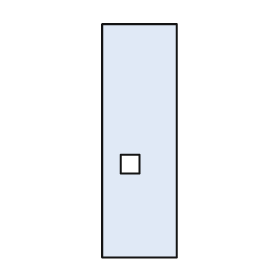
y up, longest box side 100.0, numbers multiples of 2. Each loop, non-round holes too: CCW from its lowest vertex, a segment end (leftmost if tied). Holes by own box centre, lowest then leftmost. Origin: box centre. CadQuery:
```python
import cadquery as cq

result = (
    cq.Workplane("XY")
    .moveTo(-16.0, -50.0)
    .lineTo(16.0, -50.0)
    .lineTo(16.0, 50.0)
    .lineTo(-16.0, 50.0)
    .close()
    .moveTo(-8.0, -14.0)
    .lineTo(0.0, -14.0)
    .lineTo(0.0, -6.0)
    .lineTo(-8.0, -6.0)
    .close()
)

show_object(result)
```